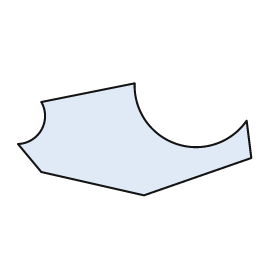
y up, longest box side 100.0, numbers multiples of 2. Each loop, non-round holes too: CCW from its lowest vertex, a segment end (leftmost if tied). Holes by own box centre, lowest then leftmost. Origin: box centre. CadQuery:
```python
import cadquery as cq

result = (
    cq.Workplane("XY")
    .moveTo(4.0, -24.0)
    .lineTo(50.0, -8.0)
    .lineTo(48.0, 8.0)
    .threePointArc((18.0, -2.0), (0.0, 24.0))
    .lineTo(-40.0, 16.0)
    .threePointArc((-40.0, 4.0), (-50.0, -2.0))
    .lineTo(-40.0, -14.0)
    .close()
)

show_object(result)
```